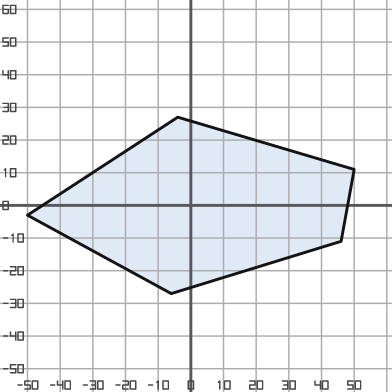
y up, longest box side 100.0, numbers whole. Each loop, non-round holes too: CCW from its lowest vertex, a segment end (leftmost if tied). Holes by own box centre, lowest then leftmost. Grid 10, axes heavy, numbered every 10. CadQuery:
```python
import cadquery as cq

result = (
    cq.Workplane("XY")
    .moveTo(-6.0, -27.0)
    .lineTo(46.0, -11.0)
    .lineTo(50.0, 11.0)
    .lineTo(-4.0, 27.0)
    .lineTo(-50.0, -3.0)
    .close()
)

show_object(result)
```